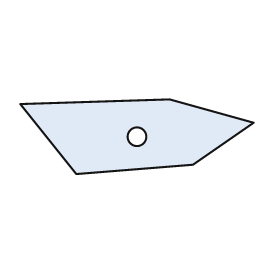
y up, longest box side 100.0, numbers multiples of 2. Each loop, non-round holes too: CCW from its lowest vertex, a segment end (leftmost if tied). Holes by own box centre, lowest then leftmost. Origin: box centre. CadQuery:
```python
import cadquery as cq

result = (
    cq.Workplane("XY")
    .moveTo(-26.0, -16.0)
    .lineTo(24.0, -12.0)
    .lineTo(50.0, 6.0)
    .lineTo(14.0, 16.0)
    .lineTo(-50.0, 14.0)
    .close()
    .moveTo(0.0, 0.0)
    .circle(4.0)
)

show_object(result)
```